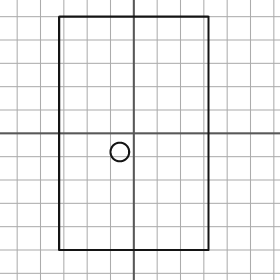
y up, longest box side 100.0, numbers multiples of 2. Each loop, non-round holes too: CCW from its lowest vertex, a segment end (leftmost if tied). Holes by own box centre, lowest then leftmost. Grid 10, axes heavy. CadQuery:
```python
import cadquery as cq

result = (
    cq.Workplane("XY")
    .moveTo(-32.0, -50.0)
    .lineTo(32.0, -50.0)
    .lineTo(32.0, 50.0)
    .lineTo(-32.0, 50.0)
    .close()
    .moveTo(-6.0, -8.0)
    .circle(4.0)
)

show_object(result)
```